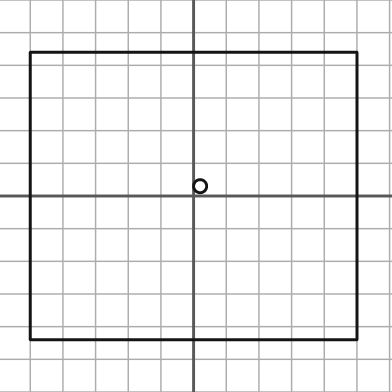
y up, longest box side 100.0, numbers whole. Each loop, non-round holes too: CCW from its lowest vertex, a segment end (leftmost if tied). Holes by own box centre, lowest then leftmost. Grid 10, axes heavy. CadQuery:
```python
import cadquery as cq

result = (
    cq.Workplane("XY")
    .moveTo(-50.0, -44.0)
    .lineTo(50.0, -44.0)
    .lineTo(50.0, 44.0)
    .lineTo(-50.0, 44.0)
    .close()
    .moveTo(2.0, 3.0)
    .circle(2.0)
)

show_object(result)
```